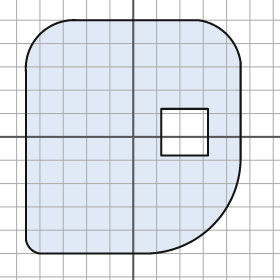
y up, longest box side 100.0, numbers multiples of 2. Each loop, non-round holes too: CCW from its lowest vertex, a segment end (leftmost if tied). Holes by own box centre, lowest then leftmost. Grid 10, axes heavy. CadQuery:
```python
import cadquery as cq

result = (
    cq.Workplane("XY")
    .moveTo(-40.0, -50.0)
    .lineTo(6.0, -50.0)
    .threePointArc((34.0, -38.0), (46.0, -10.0))
    .lineTo(46.0, 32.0)
    .threePointArc((40.0, 44.0), (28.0, 50.0))
    .lineTo(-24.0, 50.0)
    .threePointArc((-40.0, 44.0), (-46.0, 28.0))
    .lineTo(-46.0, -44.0)
    .threePointArc((-44.0, -48.0), (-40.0, -50.0))
    .close()
    .moveTo(12.0, -8.0)
    .lineTo(32.0, -8.0)
    .lineTo(32.0, 12.0)
    .lineTo(12.0, 12.0)
    .close()
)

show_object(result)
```